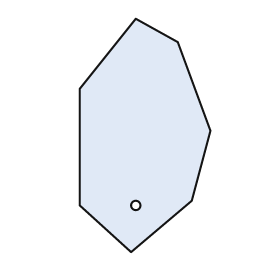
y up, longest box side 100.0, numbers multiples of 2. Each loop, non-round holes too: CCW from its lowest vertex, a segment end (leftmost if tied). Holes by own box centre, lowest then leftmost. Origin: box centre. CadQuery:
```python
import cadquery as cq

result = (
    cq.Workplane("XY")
    .moveTo(-6.0, -50.0)
    .lineTo(20.0, -28.0)
    .lineTo(28.0, 2.0)
    .lineTo(14.0, 40.0)
    .lineTo(-4.0, 50.0)
    .lineTo(-28.0, 20.0)
    .lineTo(-28.0, -30.0)
    .close()
    .moveTo(-4.0, -30.0)
    .circle(2.0)
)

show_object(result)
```